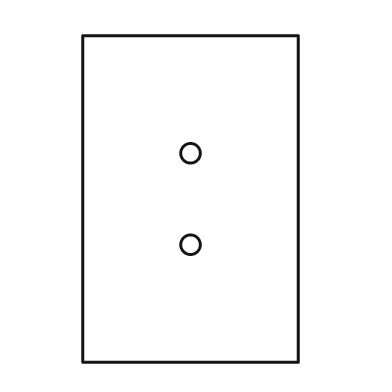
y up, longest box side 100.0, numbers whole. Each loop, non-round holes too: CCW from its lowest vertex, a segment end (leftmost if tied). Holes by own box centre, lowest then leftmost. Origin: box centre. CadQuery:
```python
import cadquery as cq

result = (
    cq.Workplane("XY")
    .moveTo(-33.0, -50.0)
    .lineTo(33.0, -50.0)
    .lineTo(33.0, 50.0)
    .lineTo(-33.0, 50.0)
    .close()
    .moveTo(0.0, -14.0)
    .circle(3.0)
    .moveTo(0.0, 14.0)
    .circle(3.0)
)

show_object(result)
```